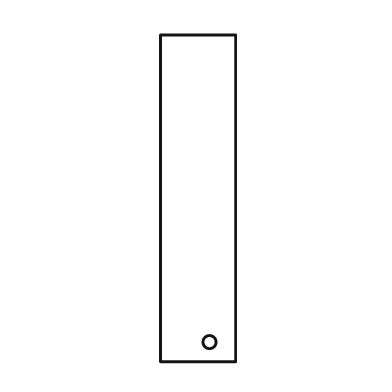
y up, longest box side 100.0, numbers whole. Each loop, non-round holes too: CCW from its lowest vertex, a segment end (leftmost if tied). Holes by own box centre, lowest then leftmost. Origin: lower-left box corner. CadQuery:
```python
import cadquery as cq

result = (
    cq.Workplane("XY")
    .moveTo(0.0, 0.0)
    .lineTo(23.0, 0.0)
    .lineTo(23.0, 100.0)
    .lineTo(0.0, 100.0)
    .close()
    .moveTo(15.0, 6.0)
    .circle(2.0)
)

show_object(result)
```